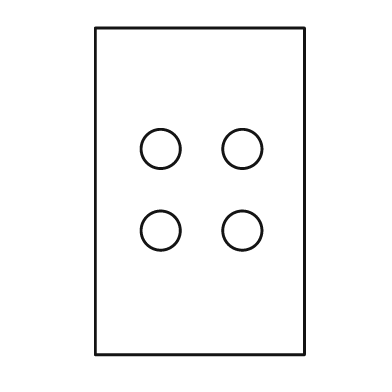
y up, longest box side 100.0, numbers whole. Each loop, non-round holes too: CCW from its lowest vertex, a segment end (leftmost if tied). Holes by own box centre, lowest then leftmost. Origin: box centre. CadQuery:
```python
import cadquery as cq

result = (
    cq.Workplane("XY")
    .moveTo(-32.0, -50.0)
    .lineTo(32.0, -50.0)
    .lineTo(32.0, 50.0)
    .lineTo(-32.0, 50.0)
    .close()
    .moveTo(-12.0, -12.0)
    .circle(6.0)
    .moveTo(13.0, -12.0)
    .circle(6.0)
    .moveTo(-12.0, 13.0)
    .circle(6.0)
    .moveTo(13.0, 13.0)
    .circle(6.0)
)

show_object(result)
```